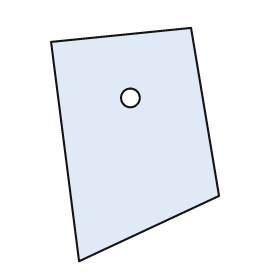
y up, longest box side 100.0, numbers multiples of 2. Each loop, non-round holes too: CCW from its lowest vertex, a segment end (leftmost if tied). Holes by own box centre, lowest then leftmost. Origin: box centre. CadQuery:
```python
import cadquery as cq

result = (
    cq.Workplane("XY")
    .moveTo(-24.0, -50.0)
    .lineTo(36.0, -22.0)
    .lineTo(24.0, 50.0)
    .lineTo(-36.0, 44.0)
    .close()
    .moveTo(-2.0, 20.0)
    .circle(4.0)
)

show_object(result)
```